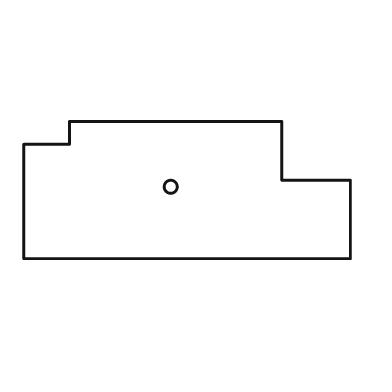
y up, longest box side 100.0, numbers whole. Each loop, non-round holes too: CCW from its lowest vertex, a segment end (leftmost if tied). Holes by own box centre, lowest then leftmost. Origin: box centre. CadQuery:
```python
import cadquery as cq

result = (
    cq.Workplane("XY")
    .moveTo(-50.0, -21.0)
    .lineTo(50.0, -21.0)
    .lineTo(50.0, 3.0)
    .lineTo(29.0, 3.0)
    .lineTo(29.0, 21.0)
    .lineTo(-36.0, 21.0)
    .lineTo(-36.0, 14.0)
    .lineTo(-50.0, 14.0)
    .close()
    .moveTo(-5.0, 1.0)
    .circle(2.0)
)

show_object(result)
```